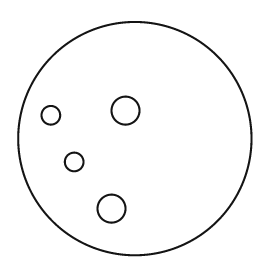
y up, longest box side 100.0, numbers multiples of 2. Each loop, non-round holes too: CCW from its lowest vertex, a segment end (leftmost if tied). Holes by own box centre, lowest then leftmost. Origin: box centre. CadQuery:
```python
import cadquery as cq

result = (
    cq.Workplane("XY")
    .moveTo(0.0, 0.0)
    .circle(50.0)
    .moveTo(-10.0, -30.0)
    .circle(6.0)
    .moveTo(-26.0, -10.0)
    .circle(4.0)
    .moveTo(-36.0, 10.0)
    .circle(4.0)
    .moveTo(-4.0, 12.0)
    .circle(6.0)
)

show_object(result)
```